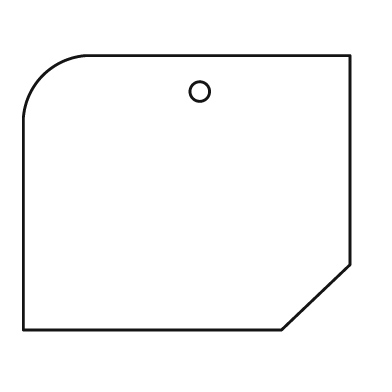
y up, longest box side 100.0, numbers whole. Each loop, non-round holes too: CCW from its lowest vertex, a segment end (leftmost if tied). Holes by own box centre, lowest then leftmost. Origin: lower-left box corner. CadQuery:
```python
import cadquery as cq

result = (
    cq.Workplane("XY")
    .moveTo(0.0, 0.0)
    .lineTo(79.0, 0.0)
    .lineTo(100.0, 20.0)
    .lineTo(100.0, 84.0)
    .lineTo(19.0, 84.0)
    .threePointArc((6.0, 78.0), (0.0, 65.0))
    .close()
    .moveTo(54.0, 73.0)
    .circle(3.0)
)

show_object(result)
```